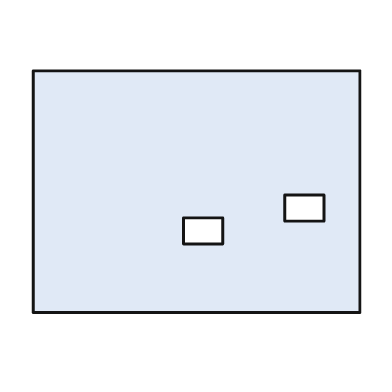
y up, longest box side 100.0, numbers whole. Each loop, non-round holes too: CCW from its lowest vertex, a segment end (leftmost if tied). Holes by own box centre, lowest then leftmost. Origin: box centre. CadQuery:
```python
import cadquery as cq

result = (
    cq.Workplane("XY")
    .moveTo(-50.0, -37.0)
    .lineTo(50.0, -37.0)
    .lineTo(50.0, 37.0)
    .lineTo(-50.0, 37.0)
    .close()
    .moveTo(-4.0, -16.0)
    .lineTo(8.0, -16.0)
    .lineTo(8.0, -8.0)
    .lineTo(-4.0, -8.0)
    .close()
    .moveTo(27.0, -9.0)
    .lineTo(39.0, -9.0)
    .lineTo(39.0, -1.0)
    .lineTo(27.0, -1.0)
    .close()
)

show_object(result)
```